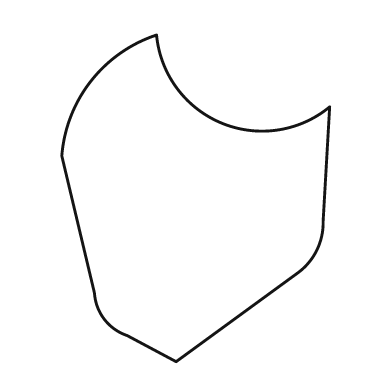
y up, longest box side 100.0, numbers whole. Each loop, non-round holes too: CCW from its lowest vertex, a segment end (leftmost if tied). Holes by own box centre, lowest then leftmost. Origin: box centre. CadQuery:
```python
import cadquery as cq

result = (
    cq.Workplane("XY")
    .moveTo(-6.0, -50.0)
    .lineTo(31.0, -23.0)
    .threePointArc((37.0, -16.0), (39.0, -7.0))
    .lineTo(41.0, 28.0)
    .threePointArc((8.0, 23.0), (-12.0, 50.0))
    .threePointArc((-32.0, 36.0), (-41.0, 13.0))
    .lineTo(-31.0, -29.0)
    .threePointArc((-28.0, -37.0), (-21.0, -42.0))
    .close()
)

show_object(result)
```